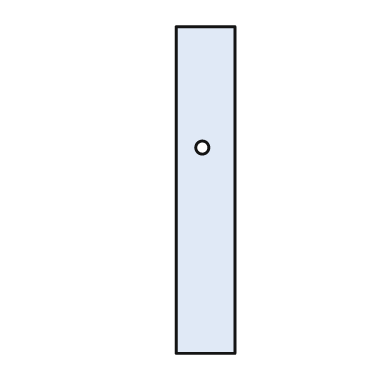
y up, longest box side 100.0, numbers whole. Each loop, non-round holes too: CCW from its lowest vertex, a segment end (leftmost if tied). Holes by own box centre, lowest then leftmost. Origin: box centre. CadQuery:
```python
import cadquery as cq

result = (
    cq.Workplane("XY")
    .moveTo(-9.0, -50.0)
    .lineTo(9.0, -50.0)
    .lineTo(9.0, 50.0)
    .lineTo(-9.0, 50.0)
    .close()
    .moveTo(-1.0, 13.0)
    .circle(2.0)
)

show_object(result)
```